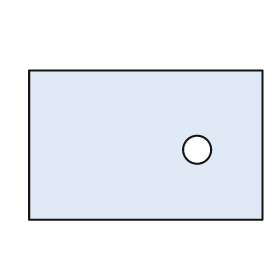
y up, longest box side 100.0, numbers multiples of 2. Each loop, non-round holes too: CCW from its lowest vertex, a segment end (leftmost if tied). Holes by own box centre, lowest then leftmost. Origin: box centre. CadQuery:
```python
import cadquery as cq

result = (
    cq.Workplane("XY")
    .moveTo(-50.0, -32.0)
    .lineTo(50.0, -32.0)
    .lineTo(50.0, 32.0)
    .lineTo(-50.0, 32.0)
    .close()
    .moveTo(22.0, -2.0)
    .circle(6.0)
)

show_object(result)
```